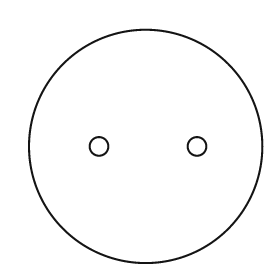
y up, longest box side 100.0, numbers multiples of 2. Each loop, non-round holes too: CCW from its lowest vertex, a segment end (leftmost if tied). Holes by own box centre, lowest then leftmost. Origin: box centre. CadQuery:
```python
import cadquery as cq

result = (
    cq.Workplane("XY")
    .moveTo(0.0, 0.0)
    .circle(50.0)
    .moveTo(-20.0, 0.0)
    .circle(4.0)
    .moveTo(22.0, 0.0)
    .circle(4.0)
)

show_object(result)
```